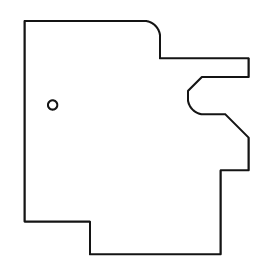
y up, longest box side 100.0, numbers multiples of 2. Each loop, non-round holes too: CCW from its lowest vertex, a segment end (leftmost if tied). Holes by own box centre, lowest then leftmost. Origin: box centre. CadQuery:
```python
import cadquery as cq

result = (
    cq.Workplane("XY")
    .moveTo(-20.0, -50.0)
    .lineTo(36.0, -50.0)
    .lineTo(36.0, -14.0)
    .lineTo(48.0, -14.0)
    .lineTo(48.0, 0.0)
    .lineTo(38.0, 10.0)
    .lineTo(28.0, 10.0)
    .threePointArc((24.0, 12.0), (22.0, 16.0))
    .lineTo(22.0, 20.0)
    .lineTo(28.0, 26.0)
    .lineTo(48.0, 26.0)
    .lineTo(48.0, 34.0)
    .lineTo(10.0, 34.0)
    .lineTo(10.0, 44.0)
    .threePointArc((8.0, 48.0), (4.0, 50.0))
    .lineTo(-48.0, 50.0)
    .lineTo(-48.0, -36.0)
    .lineTo(-20.0, -36.0)
    .close()
    .moveTo(-36.0, 14.0)
    .circle(2.0)
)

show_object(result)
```